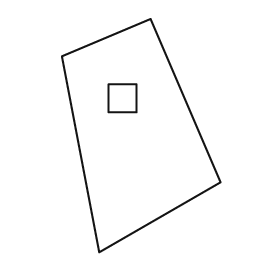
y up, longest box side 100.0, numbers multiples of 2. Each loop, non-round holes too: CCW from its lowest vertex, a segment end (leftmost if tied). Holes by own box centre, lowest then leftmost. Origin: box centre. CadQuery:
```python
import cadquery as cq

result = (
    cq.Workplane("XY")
    .moveTo(-18.0, -50.0)
    .lineTo(34.0, -20.0)
    .lineTo(4.0, 50.0)
    .lineTo(-34.0, 34.0)
    .close()
    .moveTo(-14.0, 10.0)
    .lineTo(-2.0, 10.0)
    .lineTo(-2.0, 22.0)
    .lineTo(-14.0, 22.0)
    .close()
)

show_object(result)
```